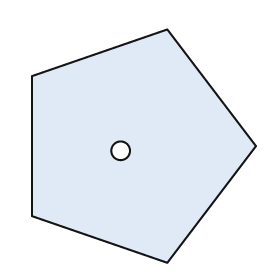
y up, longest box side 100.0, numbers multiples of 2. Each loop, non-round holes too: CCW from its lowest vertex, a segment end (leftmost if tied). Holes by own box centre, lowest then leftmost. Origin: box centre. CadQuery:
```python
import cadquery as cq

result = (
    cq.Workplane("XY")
    .moveTo(10.0, -50.0)
    .lineTo(48.0, 0.0)
    .lineTo(10.0, 50.0)
    .lineTo(-48.0, 30.0)
    .lineTo(-48.0, -30.0)
    .close()
    .moveTo(-10.0, -2.0)
    .circle(4.0)
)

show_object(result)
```